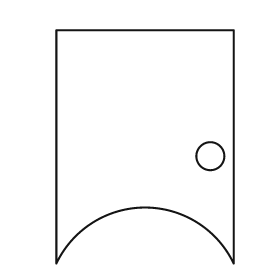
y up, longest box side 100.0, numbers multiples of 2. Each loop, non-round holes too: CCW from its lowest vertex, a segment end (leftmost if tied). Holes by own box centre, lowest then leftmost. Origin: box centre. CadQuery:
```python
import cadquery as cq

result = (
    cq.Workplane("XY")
    .moveTo(-38.0, -50.0)
    .threePointArc((0.0, -26.0), (38.0, -50.0))
    .lineTo(38.0, 50.0)
    .lineTo(-38.0, 50.0)
    .close()
    .moveTo(28.0, -4.0)
    .circle(6.0)
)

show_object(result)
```